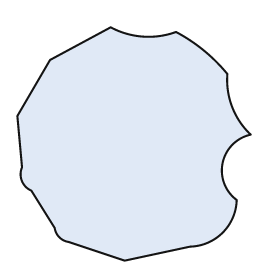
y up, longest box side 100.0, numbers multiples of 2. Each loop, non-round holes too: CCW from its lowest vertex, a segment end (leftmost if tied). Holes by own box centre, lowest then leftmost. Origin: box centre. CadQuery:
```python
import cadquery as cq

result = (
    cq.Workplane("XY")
    .moveTo(-4.0, -50.0)
    .lineTo(24.0, -44.0)
    .threePointArc((38.0, -38.0), (44.0, -24.0))
    .threePointArc((38.0, -8.0), (50.0, 4.0))
    .threePointArc((42.0, 16.0), (40.0, 30.0))
    .threePointArc((30.0, 40.0), (18.0, 48.0))
    .threePointArc((4.0, 46.0), (-10.0, 50.0))
    .lineTo(-36.0, 36.0)
    .lineTo(-50.0, 12.0)
    .lineTo(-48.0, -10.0)
    .threePointArc((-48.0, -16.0), (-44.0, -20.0))
    .lineTo(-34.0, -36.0)
    .threePointArc((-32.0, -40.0), (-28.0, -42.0))
    .close()
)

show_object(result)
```